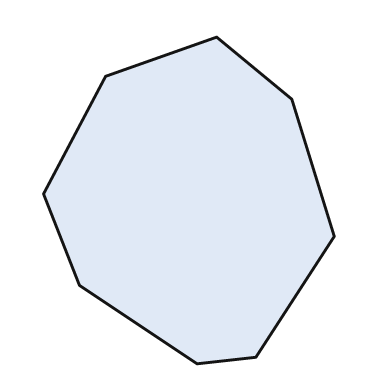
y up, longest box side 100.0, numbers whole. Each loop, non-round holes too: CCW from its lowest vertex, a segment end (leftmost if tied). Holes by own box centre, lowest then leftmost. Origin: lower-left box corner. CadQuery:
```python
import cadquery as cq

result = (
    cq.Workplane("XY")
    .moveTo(47.0, 0.0)
    .lineTo(65.0, 2.0)
    .lineTo(89.0, 39.0)
    .lineTo(76.0, 81.0)
    .lineTo(53.0, 100.0)
    .lineTo(19.0, 88.0)
    .lineTo(0.0, 52.0)
    .lineTo(11.0, 24.0)
    .close()
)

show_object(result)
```